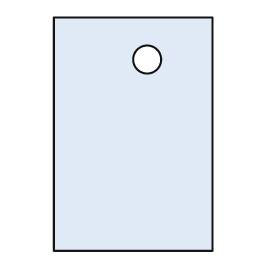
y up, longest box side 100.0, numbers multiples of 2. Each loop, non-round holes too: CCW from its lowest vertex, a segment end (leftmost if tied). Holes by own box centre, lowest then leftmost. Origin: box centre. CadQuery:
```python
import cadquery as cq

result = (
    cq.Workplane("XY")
    .moveTo(-34.0, -50.0)
    .lineTo(34.0, -50.0)
    .lineTo(34.0, 50.0)
    .lineTo(-34.0, 50.0)
    .close()
    .moveTo(6.0, 32.0)
    .circle(6.0)
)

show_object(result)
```